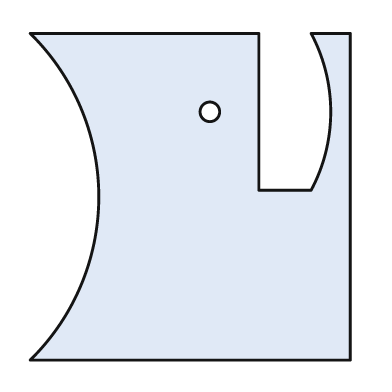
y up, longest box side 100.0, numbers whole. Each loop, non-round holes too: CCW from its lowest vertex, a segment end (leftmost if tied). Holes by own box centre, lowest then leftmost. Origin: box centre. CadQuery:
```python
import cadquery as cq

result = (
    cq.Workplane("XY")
    .moveTo(-49.0, -50.0)
    .lineTo(49.0, -50.0)
    .lineTo(49.0, 50.0)
    .lineTo(37.0, 50.0)
    .threePointArc((43.0, 26.0), (37.0, 2.0))
    .lineTo(21.0, 2.0)
    .lineTo(21.0, 50.0)
    .lineTo(-49.0, 50.0)
    .threePointArc((-28.0, 0.0), (-49.0, -50.0))
    .close()
    .moveTo(6.0, 26.0)
    .circle(3.0)
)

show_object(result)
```